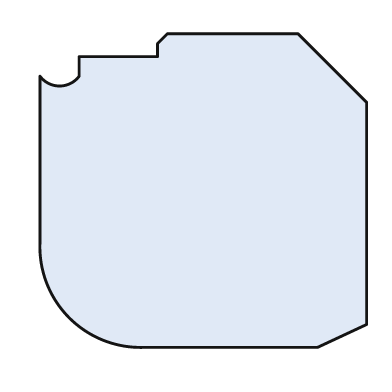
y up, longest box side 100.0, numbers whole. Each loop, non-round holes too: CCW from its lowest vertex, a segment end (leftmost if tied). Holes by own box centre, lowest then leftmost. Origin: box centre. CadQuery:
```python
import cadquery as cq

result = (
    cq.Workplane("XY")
    .moveTo(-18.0, -48.0)
    .lineTo(35.0, -48.0)
    .lineTo(50.0, -41.0)
    .lineTo(50.0, 27.0)
    .lineTo(29.0, 48.0)
    .lineTo(-11.0, 48.0)
    .lineTo(-14.0, 45.0)
    .lineTo(-14.0, 41.0)
    .lineTo(-38.0, 41.0)
    .lineTo(-38.0, 35.0)
    .threePointArc((-44.0, 32.0), (-50.0, 35.0))
    .lineTo(-50.0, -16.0)
    .threePointArc((-41.0, -39.0), (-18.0, -48.0))
    .close()
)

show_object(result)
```